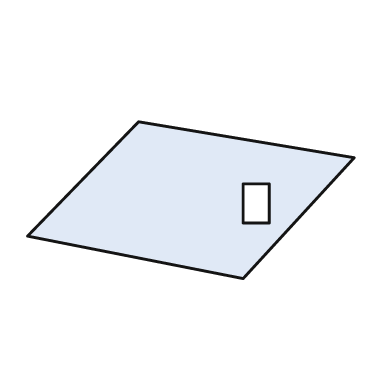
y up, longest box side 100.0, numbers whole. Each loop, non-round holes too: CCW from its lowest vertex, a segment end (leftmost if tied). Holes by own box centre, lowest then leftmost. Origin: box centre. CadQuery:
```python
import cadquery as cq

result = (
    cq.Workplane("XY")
    .moveTo(16.0, -24.0)
    .lineTo(50.0, 13.0)
    .lineTo(-16.0, 24.0)
    .lineTo(-50.0, -11.0)
    .close()
    .moveTo(16.0, -7.0)
    .lineTo(24.0, -7.0)
    .lineTo(24.0, 5.0)
    .lineTo(16.0, 5.0)
    .close()
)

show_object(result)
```